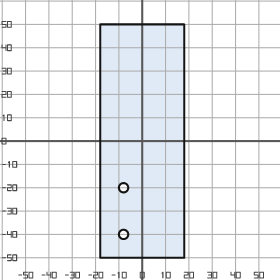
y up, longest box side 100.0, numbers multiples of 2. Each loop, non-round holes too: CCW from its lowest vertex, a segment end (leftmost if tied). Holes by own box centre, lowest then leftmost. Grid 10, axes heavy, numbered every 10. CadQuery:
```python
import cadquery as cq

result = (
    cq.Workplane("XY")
    .moveTo(-18.0, -50.0)
    .lineTo(18.0, -50.0)
    .lineTo(18.0, 50.0)
    .lineTo(-18.0, 50.0)
    .close()
    .moveTo(-8.0, -40.0)
    .circle(2.0)
    .moveTo(-8.0, -20.0)
    .circle(2.0)
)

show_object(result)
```